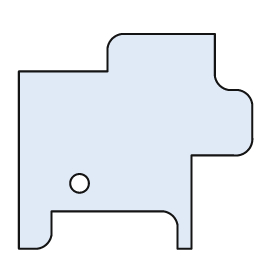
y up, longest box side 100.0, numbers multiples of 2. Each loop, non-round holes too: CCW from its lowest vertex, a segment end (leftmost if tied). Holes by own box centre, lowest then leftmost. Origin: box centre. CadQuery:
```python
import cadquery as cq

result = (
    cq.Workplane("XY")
    .moveTo(-50.0, -46.0)
    .lineTo(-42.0, -46.0)
    .threePointArc((-38.0, -44.0), (-36.0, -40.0))
    .lineTo(-36.0, -30.0)
    .lineTo(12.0, -30.0)
    .threePointArc((16.0, -32.0), (18.0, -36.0))
    .lineTo(18.0, -46.0)
    .lineTo(24.0, -46.0)
    .lineTo(24.0, -6.0)
    .lineTo(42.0, -6.0)
    .threePointArc((48.0, -4.0), (50.0, 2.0))
    .lineTo(50.0, 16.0)
    .threePointArc((48.0, 20.0), (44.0, 22.0))
    .lineTo(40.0, 22.0)
    .threePointArc((36.0, 24.0), (34.0, 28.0))
    .lineTo(34.0, 46.0)
    .lineTo(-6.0, 46.0)
    .threePointArc((-10.0, 44.0), (-12.0, 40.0))
    .lineTo(-12.0, 30.0)
    .lineTo(-50.0, 30.0)
    .close()
    .moveTo(-24.0, -18.0)
    .circle(4.0)
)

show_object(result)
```